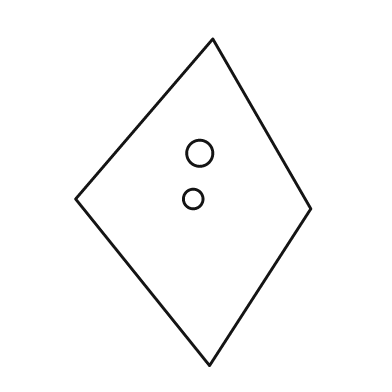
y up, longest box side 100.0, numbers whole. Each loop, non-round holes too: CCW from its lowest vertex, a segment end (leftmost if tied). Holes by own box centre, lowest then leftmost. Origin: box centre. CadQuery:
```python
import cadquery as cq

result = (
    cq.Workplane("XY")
    .moveTo(5.0, -50.0)
    .lineTo(36.0, -2.0)
    .lineTo(6.0, 50.0)
    .lineTo(-36.0, 1.0)
    .close()
    .moveTo(0.0, 1.0)
    .circle(3.0)
    .moveTo(2.0, 15.0)
    .circle(4.0)
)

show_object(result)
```